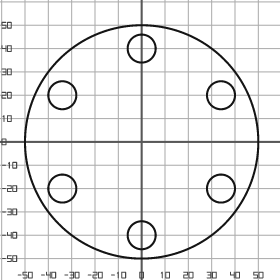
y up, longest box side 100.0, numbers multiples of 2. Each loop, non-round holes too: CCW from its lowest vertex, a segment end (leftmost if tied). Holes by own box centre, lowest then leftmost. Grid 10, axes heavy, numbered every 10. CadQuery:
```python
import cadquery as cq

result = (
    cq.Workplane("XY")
    .moveTo(0.0, 0.0)
    .circle(50.0)
    .moveTo(0.0, -40.0)
    .circle(6.0)
    .moveTo(-34.0, -20.0)
    .circle(6.0)
    .moveTo(34.0, -20.0)
    .circle(6.0)
    .moveTo(-34.0, 20.0)
    .circle(6.0)
    .moveTo(34.0, 20.0)
    .circle(6.0)
    .moveTo(0.0, 40.0)
    .circle(6.0)
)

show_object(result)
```